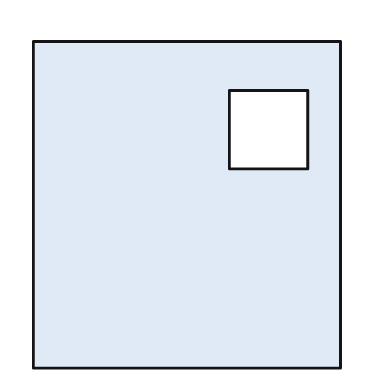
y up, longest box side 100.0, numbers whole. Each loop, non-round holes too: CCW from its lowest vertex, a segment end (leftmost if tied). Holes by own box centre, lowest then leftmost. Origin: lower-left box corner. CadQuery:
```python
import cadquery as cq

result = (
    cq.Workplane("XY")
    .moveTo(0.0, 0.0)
    .lineTo(94.0, 0.0)
    .lineTo(94.0, 100.0)
    .lineTo(0.0, 100.0)
    .close()
    .moveTo(60.0, 61.0)
    .lineTo(84.0, 61.0)
    .lineTo(84.0, 85.0)
    .lineTo(60.0, 85.0)
    .close()
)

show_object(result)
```